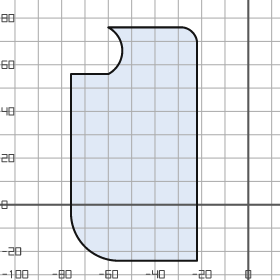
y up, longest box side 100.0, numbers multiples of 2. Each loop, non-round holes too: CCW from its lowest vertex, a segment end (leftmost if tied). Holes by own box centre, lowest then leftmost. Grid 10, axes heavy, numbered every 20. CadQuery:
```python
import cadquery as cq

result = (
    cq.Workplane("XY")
    .moveTo(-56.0, -24.0)
    .lineTo(-22.0, -24.0)
    .lineTo(-22.0, 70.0)
    .threePointArc((-24.0, 74.0), (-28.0, 76.0))
    .lineTo(-60.0, 76.0)
    .threePointArc((-54.0, 66.0), (-60.0, 56.0))
    .lineTo(-76.0, 56.0)
    .lineTo(-76.0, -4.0)
    .threePointArc((-70.0, -18.0), (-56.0, -24.0))
    .close()
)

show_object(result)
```